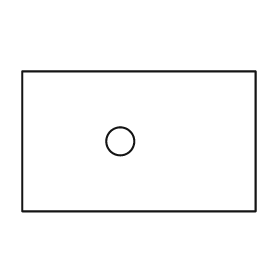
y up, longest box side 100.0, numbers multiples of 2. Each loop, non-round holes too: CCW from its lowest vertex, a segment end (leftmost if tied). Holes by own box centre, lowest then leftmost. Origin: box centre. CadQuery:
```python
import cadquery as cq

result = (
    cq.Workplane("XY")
    .moveTo(-50.0, -30.0)
    .lineTo(50.0, -30.0)
    .lineTo(50.0, 30.0)
    .lineTo(-50.0, 30.0)
    .close()
    .moveTo(-8.0, 0.0)
    .circle(6.0)
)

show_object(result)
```